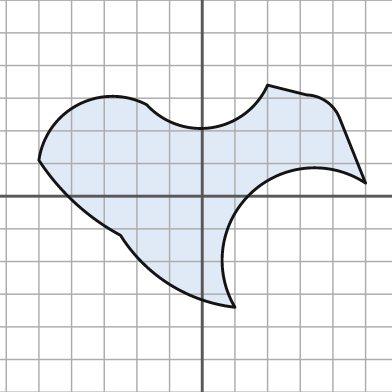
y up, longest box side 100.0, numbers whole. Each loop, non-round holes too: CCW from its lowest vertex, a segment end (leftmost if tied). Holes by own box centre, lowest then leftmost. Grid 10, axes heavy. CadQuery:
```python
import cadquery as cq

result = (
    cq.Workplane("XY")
    .moveTo(10.0, -34.0)
    .threePointArc((15.0, 1.0), (50.0, 4.0))
    .lineTo(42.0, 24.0)
    .threePointArc((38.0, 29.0), (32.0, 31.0))
    .lineTo(20.0, 34.0)
    .threePointArc((3.0, 21.0), (-17.0, 28.0))
    .threePointArc((-38.0, 28.0), (-50.0, 11.0))
    .threePointArc((-39.0, -2.0), (-25.0, -12.0))
    .threePointArc((-10.0, -27.0), (10.0, -34.0))
    .close()
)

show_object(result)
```